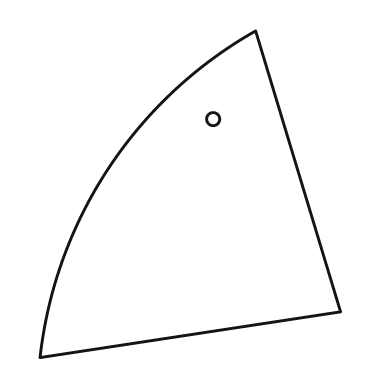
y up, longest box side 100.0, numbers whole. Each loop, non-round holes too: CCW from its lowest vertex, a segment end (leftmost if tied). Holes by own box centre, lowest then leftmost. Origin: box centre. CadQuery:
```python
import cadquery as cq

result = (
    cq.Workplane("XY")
    .moveTo(-46.0, -50.0)
    .lineTo(46.0, -36.0)
    .lineTo(20.0, 50.0)
    .threePointArc((-25.0, 8.0), (-46.0, -50.0))
    .close()
    .moveTo(7.0, 23.0)
    .circle(2.0)
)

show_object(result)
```